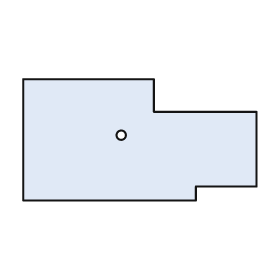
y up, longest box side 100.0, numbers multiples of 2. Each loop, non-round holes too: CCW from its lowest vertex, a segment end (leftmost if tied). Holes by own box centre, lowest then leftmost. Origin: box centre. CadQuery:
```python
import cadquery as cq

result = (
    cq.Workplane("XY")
    .moveTo(-50.0, -26.0)
    .lineTo(24.0, -26.0)
    .lineTo(24.0, -20.0)
    .lineTo(50.0, -20.0)
    .lineTo(50.0, 12.0)
    .lineTo(6.0, 12.0)
    .lineTo(6.0, 26.0)
    .lineTo(-50.0, 26.0)
    .close()
    .moveTo(-8.0, 2.0)
    .circle(2.0)
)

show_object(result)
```